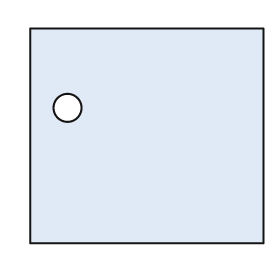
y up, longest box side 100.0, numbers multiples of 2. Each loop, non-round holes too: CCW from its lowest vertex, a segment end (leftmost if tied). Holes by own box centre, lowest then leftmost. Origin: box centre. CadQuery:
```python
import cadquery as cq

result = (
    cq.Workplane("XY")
    .moveTo(-50.0, -46.0)
    .lineTo(50.0, -46.0)
    .lineTo(50.0, 46.0)
    .lineTo(-50.0, 46.0)
    .close()
    .moveTo(-34.0, 12.0)
    .circle(6.0)
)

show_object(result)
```